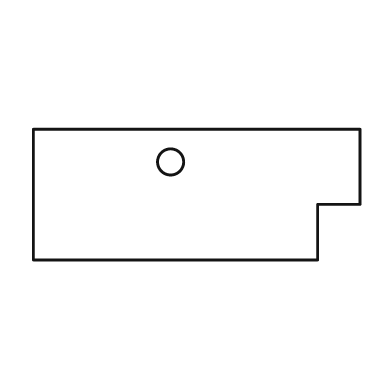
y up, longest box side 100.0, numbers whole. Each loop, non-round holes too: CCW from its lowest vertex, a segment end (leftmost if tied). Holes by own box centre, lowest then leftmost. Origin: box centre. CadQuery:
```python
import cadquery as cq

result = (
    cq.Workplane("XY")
    .moveTo(-50.0, -20.0)
    .lineTo(37.0, -20.0)
    .lineTo(37.0, -3.0)
    .lineTo(50.0, -3.0)
    .lineTo(50.0, 20.0)
    .lineTo(-50.0, 20.0)
    .close()
    .moveTo(-8.0, 10.0)
    .circle(4.0)
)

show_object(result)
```